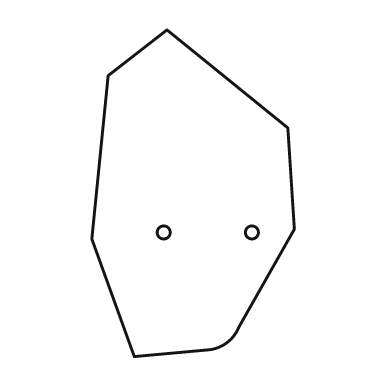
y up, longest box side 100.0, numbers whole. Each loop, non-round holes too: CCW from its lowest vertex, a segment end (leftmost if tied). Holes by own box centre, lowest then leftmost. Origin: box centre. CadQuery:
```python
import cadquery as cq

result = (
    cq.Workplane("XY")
    .moveTo(-18.0, -50.0)
    .lineTo(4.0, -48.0)
    .threePointArc((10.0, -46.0), (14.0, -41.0))
    .lineTo(31.0, -11.0)
    .lineTo(29.0, 20.0)
    .lineTo(-8.0, 50.0)
    .lineTo(-26.0, 36.0)
    .lineTo(-31.0, -14.0)
    .close()
    .moveTo(-9.0, -12.0)
    .circle(2.0)
    .moveTo(18.0, -12.0)
    .circle(2.0)
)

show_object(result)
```